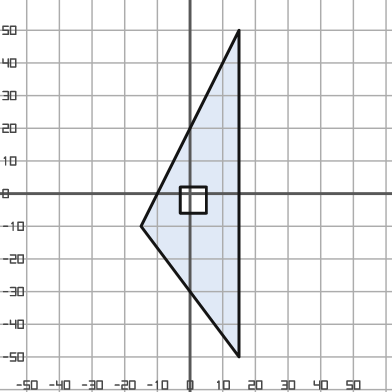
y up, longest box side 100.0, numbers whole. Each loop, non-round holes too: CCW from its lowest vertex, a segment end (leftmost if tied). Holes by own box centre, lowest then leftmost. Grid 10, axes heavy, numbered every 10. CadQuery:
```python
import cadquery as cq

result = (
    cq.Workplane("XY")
    .moveTo(15.0, -50.0)
    .lineTo(15.0, 50.0)
    .lineTo(-15.0, -10.0)
    .close()
    .moveTo(-3.0, -6.0)
    .lineTo(5.0, -6.0)
    .lineTo(5.0, 2.0)
    .lineTo(-3.0, 2.0)
    .close()
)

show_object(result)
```